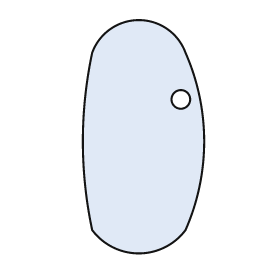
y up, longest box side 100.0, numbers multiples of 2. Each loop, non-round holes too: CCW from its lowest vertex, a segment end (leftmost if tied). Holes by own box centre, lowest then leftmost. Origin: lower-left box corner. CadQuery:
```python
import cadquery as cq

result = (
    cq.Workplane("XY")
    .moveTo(4.0, 10.0)
    .threePointArc((24.0, 0.0), (44.0, 10.0))
    .threePointArc((52.0, 48.0), (44.0, 86.0))
    .threePointArc((24.0, 100.0), (4.0, 86.0))
    .threePointArc((0.0, 48.0), (4.0, 10.0))
    .close()
    .moveTo(42.0, 66.0)
    .circle(4.0)
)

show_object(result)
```